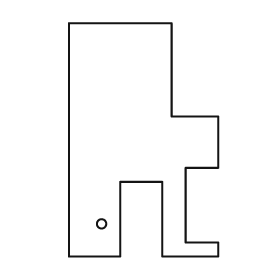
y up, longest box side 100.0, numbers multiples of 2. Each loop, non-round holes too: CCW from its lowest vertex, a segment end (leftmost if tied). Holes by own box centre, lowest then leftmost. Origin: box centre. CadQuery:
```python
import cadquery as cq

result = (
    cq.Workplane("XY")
    .moveTo(-32.0, -50.0)
    .lineTo(-10.0, -50.0)
    .lineTo(-10.0, -18.0)
    .lineTo(8.0, -18.0)
    .lineTo(8.0, -50.0)
    .lineTo(32.0, -50.0)
    .lineTo(32.0, -44.0)
    .lineTo(18.0, -44.0)
    .lineTo(18.0, -12.0)
    .lineTo(32.0, -12.0)
    .lineTo(32.0, 10.0)
    .lineTo(12.0, 10.0)
    .lineTo(12.0, 50.0)
    .lineTo(-32.0, 50.0)
    .close()
    .moveTo(-18.0, -36.0)
    .circle(2.0)
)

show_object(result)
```